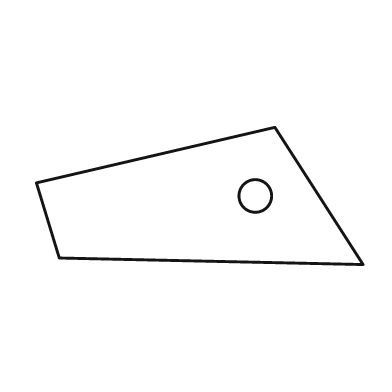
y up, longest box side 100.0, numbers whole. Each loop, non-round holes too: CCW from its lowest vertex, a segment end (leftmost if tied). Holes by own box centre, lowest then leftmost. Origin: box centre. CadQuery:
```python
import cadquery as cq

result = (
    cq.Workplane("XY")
    .moveTo(50.0, -21.0)
    .lineTo(23.0, 21.0)
    .lineTo(-50.0, 4.0)
    .lineTo(-43.0, -19.0)
    .close()
    .moveTo(17.0, 0.0)
    .circle(5.0)
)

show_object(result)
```